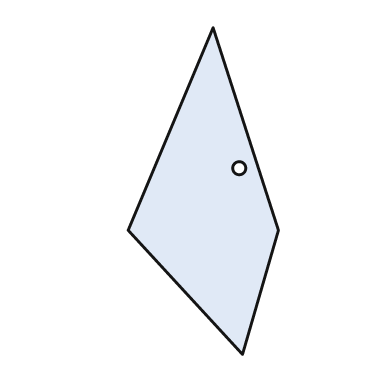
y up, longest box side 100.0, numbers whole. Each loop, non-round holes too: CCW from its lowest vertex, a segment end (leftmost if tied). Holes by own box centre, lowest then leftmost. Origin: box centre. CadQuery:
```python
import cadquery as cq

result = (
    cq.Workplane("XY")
    .moveTo(12.0, -50.0)
    .lineTo(23.0, -12.0)
    .lineTo(3.0, 50.0)
    .lineTo(-23.0, -12.0)
    .close()
    .moveTo(11.0, 7.0)
    .circle(2.0)
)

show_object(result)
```